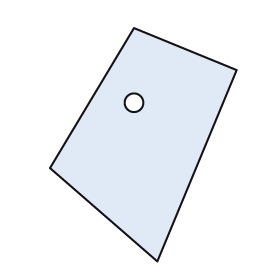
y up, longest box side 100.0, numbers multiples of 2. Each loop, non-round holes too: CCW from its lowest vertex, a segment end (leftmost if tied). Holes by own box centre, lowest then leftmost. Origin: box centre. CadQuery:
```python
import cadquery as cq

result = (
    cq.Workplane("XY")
    .moveTo(6.0, -50.0)
    .lineTo(40.0, 32.0)
    .lineTo(-4.0, 50.0)
    .lineTo(-40.0, -10.0)
    .close()
    .moveTo(-4.0, 18.0)
    .circle(4.0)
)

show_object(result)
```